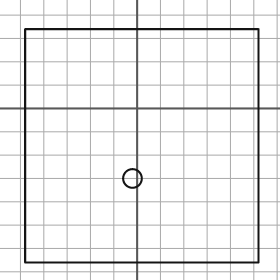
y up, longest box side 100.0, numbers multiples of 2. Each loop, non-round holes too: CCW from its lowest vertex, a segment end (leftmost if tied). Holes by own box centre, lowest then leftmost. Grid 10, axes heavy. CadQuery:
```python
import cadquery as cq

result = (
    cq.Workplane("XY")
    .moveTo(-48.0, -66.0)
    .lineTo(52.0, -66.0)
    .lineTo(52.0, 34.0)
    .lineTo(-48.0, 34.0)
    .close()
    .moveTo(-2.0, -30.0)
    .circle(4.0)
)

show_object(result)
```